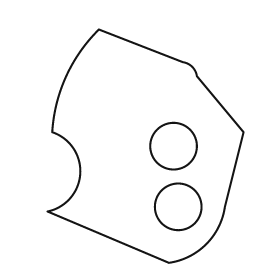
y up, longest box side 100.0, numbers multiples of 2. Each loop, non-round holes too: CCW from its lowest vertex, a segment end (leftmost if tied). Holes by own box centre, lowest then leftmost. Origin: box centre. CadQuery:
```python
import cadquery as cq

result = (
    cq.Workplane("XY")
    .moveTo(10.0, -50.0)
    .threePointArc((26.0, -42.0), (34.0, -26.0))
    .lineTo(42.0, 6.0)
    .lineTo(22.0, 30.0)
    .threePointArc((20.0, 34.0), (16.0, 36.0))
    .lineTo(-20.0, 50.0)
    .threePointArc((-34.0, 30.0), (-40.0, 6.0))
    .threePointArc((-28.0, -12.0), (-42.0, -28.0))
    .close()
    .moveTo(14.0, -26.0)
    .circle(10.0)
    .moveTo(12.0, 0.0)
    .circle(10.0)
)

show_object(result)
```